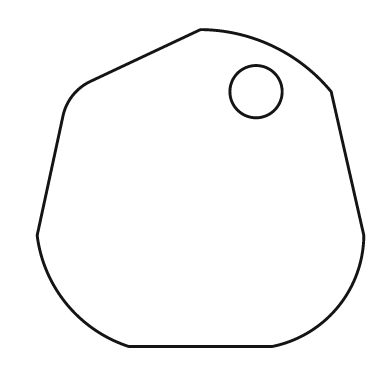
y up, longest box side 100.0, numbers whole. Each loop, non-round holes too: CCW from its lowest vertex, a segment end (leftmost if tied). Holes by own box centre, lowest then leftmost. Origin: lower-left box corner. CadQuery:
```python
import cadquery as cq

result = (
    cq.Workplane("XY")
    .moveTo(28.0, 0.0)
    .lineTo(72.0, 0.0)
    .threePointArc((92.0, 12.0), (100.0, 34.0))
    .lineTo(90.0, 78.0)
    .threePointArc((72.0, 92.0), (50.0, 97.0))
    .lineTo(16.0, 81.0)
    .threePointArc((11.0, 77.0), (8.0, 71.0))
    .lineTo(0.0, 34.0)
    .threePointArc((9.0, 13.0), (28.0, 0.0))
    .close()
    .moveTo(67.0, 78.0)
    .circle(8.0)
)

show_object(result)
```